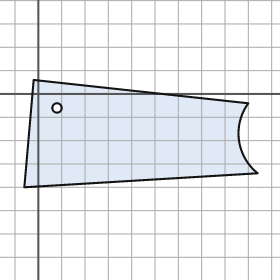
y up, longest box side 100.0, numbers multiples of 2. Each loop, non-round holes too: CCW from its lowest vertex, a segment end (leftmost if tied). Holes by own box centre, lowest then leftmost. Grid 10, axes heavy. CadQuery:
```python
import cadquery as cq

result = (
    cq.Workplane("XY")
    .moveTo(-6.0, -40.0)
    .lineTo(94.0, -34.0)
    .threePointArc((86.0, -20.0), (90.0, -4.0))
    .lineTo(-2.0, 6.0)
    .close()
    .moveTo(8.0, -6.0)
    .circle(2.0)
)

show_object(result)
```